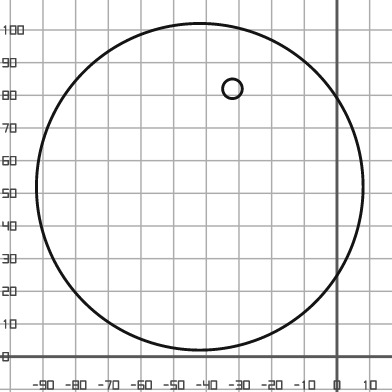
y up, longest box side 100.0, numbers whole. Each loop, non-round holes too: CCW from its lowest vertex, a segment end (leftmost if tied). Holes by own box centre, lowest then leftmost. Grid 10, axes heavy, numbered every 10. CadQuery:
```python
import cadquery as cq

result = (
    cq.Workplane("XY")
    .moveTo(-42.0, 52.0)
    .circle(50.0)
    .moveTo(-32.0, 82.0)
    .circle(3.0)
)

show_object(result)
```